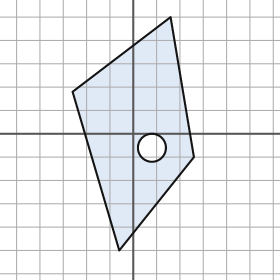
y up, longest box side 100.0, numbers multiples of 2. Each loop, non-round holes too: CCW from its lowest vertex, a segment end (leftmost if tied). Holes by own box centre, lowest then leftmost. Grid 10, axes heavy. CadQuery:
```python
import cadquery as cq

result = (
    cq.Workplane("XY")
    .moveTo(-6.0, -50.0)
    .lineTo(26.0, -10.0)
    .lineTo(16.0, 50.0)
    .lineTo(-26.0, 18.0)
    .close()
    .moveTo(8.0, -6.0)
    .circle(6.0)
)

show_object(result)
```